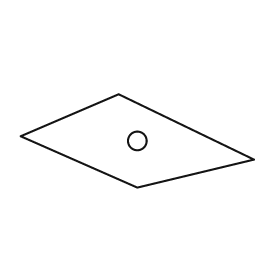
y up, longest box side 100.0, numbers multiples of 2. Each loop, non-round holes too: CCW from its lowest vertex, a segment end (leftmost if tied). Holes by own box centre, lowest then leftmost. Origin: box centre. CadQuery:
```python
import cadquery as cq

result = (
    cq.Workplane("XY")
    .moveTo(0.0, -20.0)
    .lineTo(50.0, -8.0)
    .lineTo(-8.0, 20.0)
    .lineTo(-50.0, 2.0)
    .close()
    .moveTo(0.0, 0.0)
    .circle(4.0)
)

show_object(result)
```